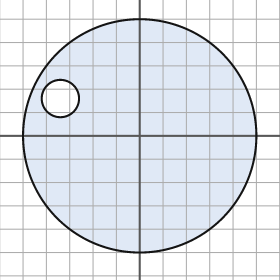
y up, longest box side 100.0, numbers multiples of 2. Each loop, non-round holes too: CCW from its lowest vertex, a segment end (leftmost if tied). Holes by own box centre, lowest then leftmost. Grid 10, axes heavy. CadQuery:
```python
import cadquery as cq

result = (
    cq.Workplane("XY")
    .moveTo(0.0, 0.0)
    .circle(50.0)
    .moveTo(-34.0, 16.0)
    .circle(8.0)
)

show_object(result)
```